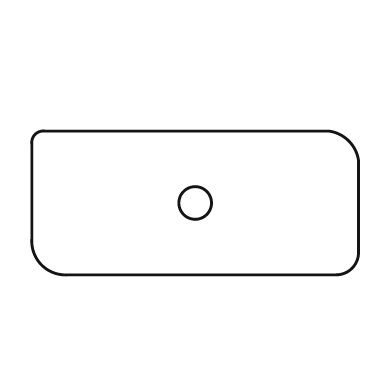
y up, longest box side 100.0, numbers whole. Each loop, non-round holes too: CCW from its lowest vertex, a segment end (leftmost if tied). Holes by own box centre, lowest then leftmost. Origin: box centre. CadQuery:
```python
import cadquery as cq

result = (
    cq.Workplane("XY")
    .moveTo(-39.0, -22.0)
    .lineTo(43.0, -22.0)
    .threePointArc((48.0, -20.0), (50.0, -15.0))
    .lineTo(50.0, 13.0)
    .threePointArc((47.0, 19.0), (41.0, 22.0))
    .lineTo(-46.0, 22.0)
    .threePointArc((-49.0, 21.0), (-50.0, 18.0))
    .lineTo(-50.0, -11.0)
    .threePointArc((-47.0, -19.0), (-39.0, -22.0))
    .close()
    .moveTo(0.0, 0.0)
    .circle(5.0)
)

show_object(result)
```